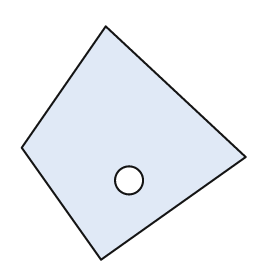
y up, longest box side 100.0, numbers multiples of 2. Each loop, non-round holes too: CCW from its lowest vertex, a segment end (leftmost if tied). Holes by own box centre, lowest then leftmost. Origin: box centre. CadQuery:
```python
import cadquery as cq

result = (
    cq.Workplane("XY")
    .moveTo(-14.0, -50.0)
    .lineTo(48.0, -6.0)
    .lineTo(-12.0, 50.0)
    .lineTo(-48.0, -2.0)
    .close()
    .moveTo(-2.0, -16.0)
    .circle(6.0)
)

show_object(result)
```